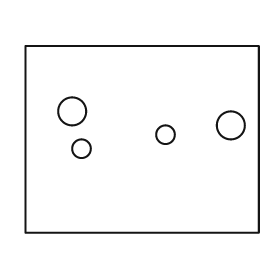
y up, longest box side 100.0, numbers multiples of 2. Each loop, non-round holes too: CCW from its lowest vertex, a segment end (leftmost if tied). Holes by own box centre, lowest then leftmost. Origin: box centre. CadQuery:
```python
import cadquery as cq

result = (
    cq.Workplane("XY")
    .moveTo(-50.0, -40.0)
    .lineTo(50.0, -40.0)
    .lineTo(50.0, 40.0)
    .lineTo(-50.0, 40.0)
    .close()
    .moveTo(-26.0, -4.0)
    .circle(4.0)
    .moveTo(10.0, 2.0)
    .circle(4.0)
    .moveTo(38.0, 6.0)
    .circle(6.0)
    .moveTo(-30.0, 12.0)
    .circle(6.0)
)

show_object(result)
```